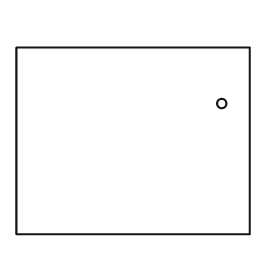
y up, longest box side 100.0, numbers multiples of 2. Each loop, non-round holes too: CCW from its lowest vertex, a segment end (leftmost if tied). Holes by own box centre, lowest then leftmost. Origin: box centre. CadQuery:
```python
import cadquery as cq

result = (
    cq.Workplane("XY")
    .moveTo(-50.0, -40.0)
    .lineTo(50.0, -40.0)
    .lineTo(50.0, 40.0)
    .lineTo(-50.0, 40.0)
    .close()
    .moveTo(38.0, 16.0)
    .circle(2.0)
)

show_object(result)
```